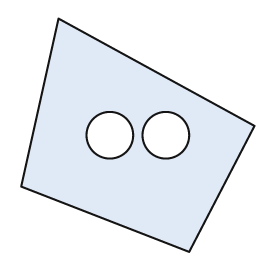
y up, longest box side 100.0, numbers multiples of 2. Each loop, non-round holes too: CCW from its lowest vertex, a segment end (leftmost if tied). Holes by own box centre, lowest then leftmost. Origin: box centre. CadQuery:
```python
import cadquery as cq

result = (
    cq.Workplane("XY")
    .moveTo(22.0, -50.0)
    .lineTo(50.0, 4.0)
    .lineTo(-34.0, 50.0)
    .lineTo(-50.0, -22.0)
    .close()
    .moveTo(-12.0, 0.0)
    .circle(10.0)
    .moveTo(12.0, 0.0)
    .circle(10.0)
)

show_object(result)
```